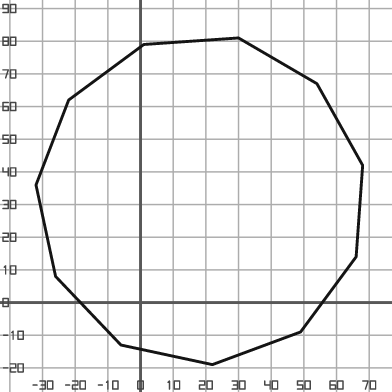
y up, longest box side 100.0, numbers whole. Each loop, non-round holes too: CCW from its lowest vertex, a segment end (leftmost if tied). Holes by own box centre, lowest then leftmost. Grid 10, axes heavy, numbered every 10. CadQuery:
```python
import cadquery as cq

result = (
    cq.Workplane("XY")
    .moveTo(22.0, -19.0)
    .lineTo(49.0, -9.0)
    .lineTo(66.0, 14.0)
    .lineTo(68.0, 42.0)
    .lineTo(54.0, 67.0)
    .lineTo(30.0, 81.0)
    .lineTo(1.0, 79.0)
    .lineTo(-22.0, 62.0)
    .lineTo(-32.0, 36.0)
    .lineTo(-26.0, 8.0)
    .lineTo(-6.0, -13.0)
    .close()
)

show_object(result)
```